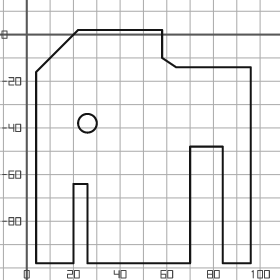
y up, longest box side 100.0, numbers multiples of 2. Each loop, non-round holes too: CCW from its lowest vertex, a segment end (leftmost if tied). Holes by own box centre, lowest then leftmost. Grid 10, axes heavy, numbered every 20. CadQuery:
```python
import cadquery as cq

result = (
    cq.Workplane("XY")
    .moveTo(4.0, -98.0)
    .lineTo(20.0, -98.0)
    .lineTo(20.0, -64.0)
    .lineTo(26.0, -64.0)
    .lineTo(26.0, -98.0)
    .lineTo(70.0, -98.0)
    .lineTo(70.0, -48.0)
    .lineTo(84.0, -48.0)
    .lineTo(84.0, -98.0)
    .lineTo(96.0, -98.0)
    .lineTo(96.0, -14.0)
    .lineTo(64.0, -14.0)
    .lineTo(58.0, -10.0)
    .lineTo(58.0, 2.0)
    .lineTo(22.0, 2.0)
    .lineTo(4.0, -16.0)
    .close()
    .moveTo(26.0, -38.0)
    .circle(4.0)
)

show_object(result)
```